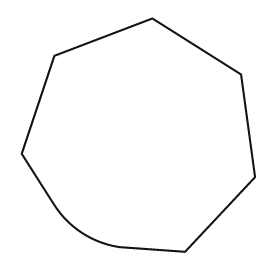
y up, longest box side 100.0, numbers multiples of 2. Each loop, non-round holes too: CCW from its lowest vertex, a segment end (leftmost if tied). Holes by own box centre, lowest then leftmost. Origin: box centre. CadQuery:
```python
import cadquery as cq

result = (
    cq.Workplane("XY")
    .moveTo(20.0, -50.0)
    .lineTo(50.0, -18.0)
    .lineTo(44.0, 26.0)
    .lineTo(6.0, 50.0)
    .lineTo(-36.0, 34.0)
    .lineTo(-50.0, -8.0)
    .lineTo(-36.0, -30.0)
    .threePointArc((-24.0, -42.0), (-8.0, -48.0))
    .close()
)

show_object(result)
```